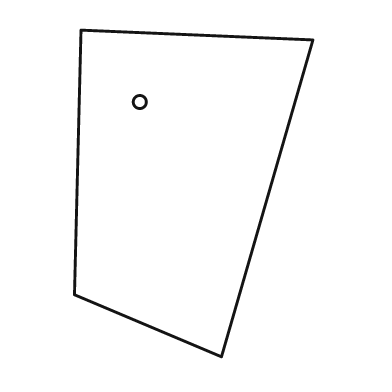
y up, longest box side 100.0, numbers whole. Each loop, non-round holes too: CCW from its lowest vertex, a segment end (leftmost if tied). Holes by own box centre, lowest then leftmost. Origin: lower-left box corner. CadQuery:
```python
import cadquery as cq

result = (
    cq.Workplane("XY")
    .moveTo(45.0, 0.0)
    .lineTo(73.0, 97.0)
    .lineTo(2.0, 100.0)
    .lineTo(0.0, 19.0)
    .close()
    .moveTo(20.0, 78.0)
    .circle(2.0)
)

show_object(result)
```